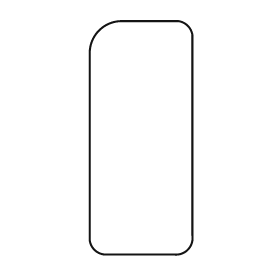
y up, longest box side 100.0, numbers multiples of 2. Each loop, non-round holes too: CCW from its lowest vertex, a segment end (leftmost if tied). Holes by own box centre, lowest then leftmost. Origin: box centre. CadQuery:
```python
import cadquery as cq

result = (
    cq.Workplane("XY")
    .moveTo(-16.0, -50.0)
    .lineTo(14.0, -50.0)
    .threePointArc((20.0, -48.0), (22.0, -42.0))
    .lineTo(22.0, 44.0)
    .threePointArc((20.0, 48.0), (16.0, 50.0))
    .lineTo(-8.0, 50.0)
    .threePointArc((-18.0, 46.0), (-22.0, 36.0))
    .lineTo(-22.0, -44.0)
    .threePointArc((-20.0, -48.0), (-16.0, -50.0))
    .close()
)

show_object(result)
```